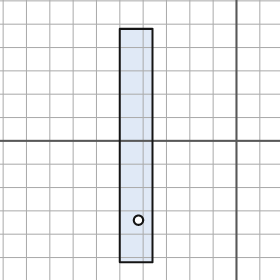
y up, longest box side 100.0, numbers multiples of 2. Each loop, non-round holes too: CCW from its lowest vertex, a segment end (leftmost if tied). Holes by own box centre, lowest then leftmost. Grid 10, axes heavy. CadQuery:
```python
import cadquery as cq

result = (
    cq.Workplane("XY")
    .moveTo(-50.0, -52.0)
    .lineTo(-36.0, -52.0)
    .lineTo(-36.0, 48.0)
    .lineTo(-50.0, 48.0)
    .close()
    .moveTo(-42.0, -34.0)
    .circle(2.0)
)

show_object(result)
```